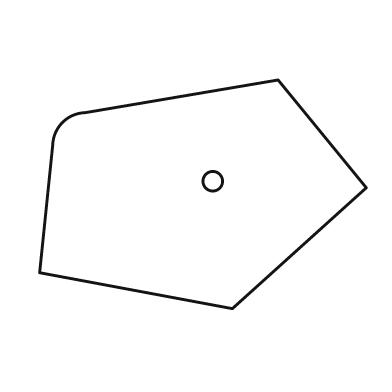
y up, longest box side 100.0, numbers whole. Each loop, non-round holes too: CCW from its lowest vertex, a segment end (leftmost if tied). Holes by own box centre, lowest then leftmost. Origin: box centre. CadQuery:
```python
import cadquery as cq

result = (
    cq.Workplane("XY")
    .moveTo(9.0, -35.0)
    .lineTo(50.0, 2.0)
    .lineTo(23.0, 35.0)
    .lineTo(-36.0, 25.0)
    .threePointArc((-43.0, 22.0), (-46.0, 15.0))
    .lineTo(-50.0, -24.0)
    .close()
    .moveTo(3.0, 4.0)
    .circle(3.0)
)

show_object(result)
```